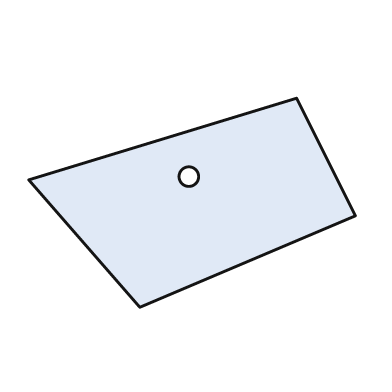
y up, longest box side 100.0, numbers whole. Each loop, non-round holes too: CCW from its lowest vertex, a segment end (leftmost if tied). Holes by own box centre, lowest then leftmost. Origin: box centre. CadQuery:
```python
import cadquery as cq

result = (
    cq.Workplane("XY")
    .moveTo(-16.0, -32.0)
    .lineTo(50.0, -4.0)
    .lineTo(32.0, 32.0)
    .lineTo(-50.0, 7.0)
    .close()
    .moveTo(-1.0, 8.0)
    .circle(3.0)
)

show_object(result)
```